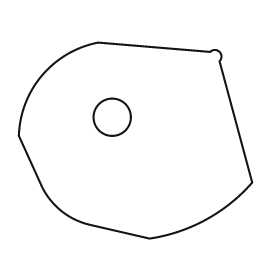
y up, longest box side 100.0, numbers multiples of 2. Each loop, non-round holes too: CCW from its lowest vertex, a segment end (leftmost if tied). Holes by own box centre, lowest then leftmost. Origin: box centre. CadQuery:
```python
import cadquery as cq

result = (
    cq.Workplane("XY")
    .moveTo(6.0, -42.0)
    .threePointArc((30.0, -34.0), (50.0, -18.0))
    .lineTo(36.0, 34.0)
    .threePointArc((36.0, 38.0), (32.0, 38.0))
    .lineTo(-16.0, 42.0)
    .threePointArc((-40.0, 28.0), (-50.0, 2.0))
    .lineTo(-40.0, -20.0)
    .threePointArc((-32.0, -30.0), (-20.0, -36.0))
    .close()
    .moveTo(-10.0, 10.0)
    .circle(8.0)
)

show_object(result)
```